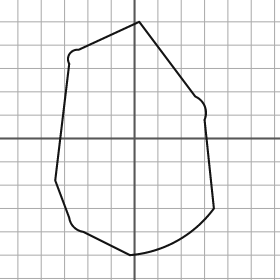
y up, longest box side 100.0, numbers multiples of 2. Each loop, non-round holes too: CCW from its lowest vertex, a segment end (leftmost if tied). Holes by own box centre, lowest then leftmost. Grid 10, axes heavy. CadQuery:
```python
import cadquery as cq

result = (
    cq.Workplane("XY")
    .moveTo(-2.0, -50.0)
    .threePointArc((18.0, -44.0), (34.0, -30.0))
    .lineTo(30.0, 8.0)
    .threePointArc((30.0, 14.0), (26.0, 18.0))
    .lineTo(2.0, 50.0)
    .lineTo(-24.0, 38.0)
    .threePointArc((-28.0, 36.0), (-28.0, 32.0))
    .lineTo(-34.0, -18.0)
    .lineTo(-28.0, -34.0)
    .threePointArc((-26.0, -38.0), (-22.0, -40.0))
    .close()
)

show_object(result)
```